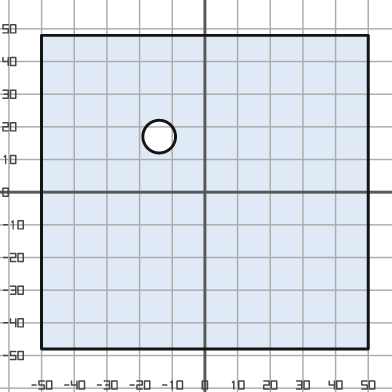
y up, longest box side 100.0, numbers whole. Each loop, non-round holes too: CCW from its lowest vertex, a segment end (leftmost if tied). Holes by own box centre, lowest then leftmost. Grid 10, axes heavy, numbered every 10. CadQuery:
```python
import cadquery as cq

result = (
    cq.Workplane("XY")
    .moveTo(-50.0, -48.0)
    .lineTo(50.0, -48.0)
    .lineTo(50.0, 48.0)
    .lineTo(-50.0, 48.0)
    .close()
    .moveTo(-14.0, 17.0)
    .circle(5.0)
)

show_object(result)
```